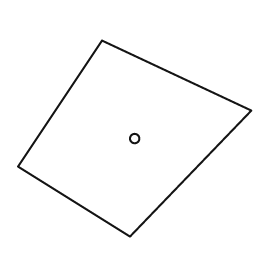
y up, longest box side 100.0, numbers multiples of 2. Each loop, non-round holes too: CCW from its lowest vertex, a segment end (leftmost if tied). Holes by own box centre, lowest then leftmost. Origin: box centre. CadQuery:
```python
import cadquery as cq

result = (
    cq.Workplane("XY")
    .moveTo(-2.0, -42.0)
    .lineTo(50.0, 12.0)
    .lineTo(-14.0, 42.0)
    .lineTo(-50.0, -12.0)
    .close()
    .moveTo(0.0, 0.0)
    .circle(2.0)
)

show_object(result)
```